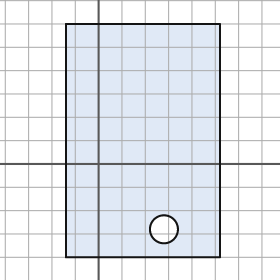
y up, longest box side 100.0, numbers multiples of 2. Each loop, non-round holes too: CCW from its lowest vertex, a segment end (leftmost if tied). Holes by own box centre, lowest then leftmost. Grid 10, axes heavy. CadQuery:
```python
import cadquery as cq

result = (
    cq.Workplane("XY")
    .moveTo(-14.0, -40.0)
    .lineTo(52.0, -40.0)
    .lineTo(52.0, 60.0)
    .lineTo(-14.0, 60.0)
    .close()
    .moveTo(28.0, -28.0)
    .circle(6.0)
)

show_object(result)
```